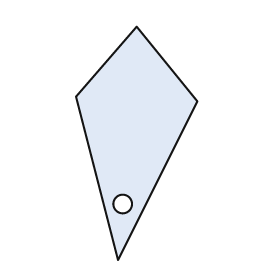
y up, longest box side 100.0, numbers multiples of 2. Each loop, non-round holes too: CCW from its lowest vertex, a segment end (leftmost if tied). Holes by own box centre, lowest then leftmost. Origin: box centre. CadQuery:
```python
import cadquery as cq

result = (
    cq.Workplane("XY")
    .moveTo(-8.0, -50.0)
    .lineTo(26.0, 18.0)
    .lineTo(0.0, 50.0)
    .lineTo(-26.0, 20.0)
    .close()
    .moveTo(-6.0, -26.0)
    .circle(4.0)
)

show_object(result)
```